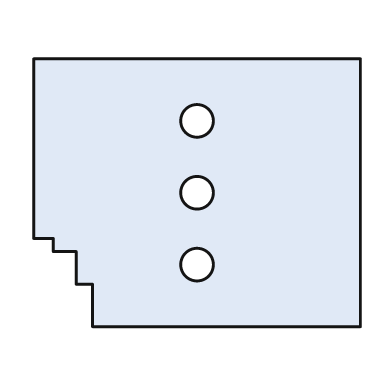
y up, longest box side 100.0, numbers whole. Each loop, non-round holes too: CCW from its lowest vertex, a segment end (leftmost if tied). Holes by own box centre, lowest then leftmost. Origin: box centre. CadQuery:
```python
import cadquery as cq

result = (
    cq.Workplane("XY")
    .moveTo(-32.0, -41.0)
    .lineTo(50.0, -41.0)
    .lineTo(50.0, 41.0)
    .lineTo(-50.0, 41.0)
    .lineTo(-50.0, -14.0)
    .lineTo(-44.0, -14.0)
    .lineTo(-44.0, -18.0)
    .lineTo(-37.0, -18.0)
    .lineTo(-37.0, -28.0)
    .lineTo(-32.0, -28.0)
    .close()
    .moveTo(0.0, -22.0)
    .circle(5.0)
    .moveTo(0.0, 0.0)
    .circle(5.0)
    .moveTo(0.0, 22.0)
    .circle(5.0)
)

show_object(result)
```